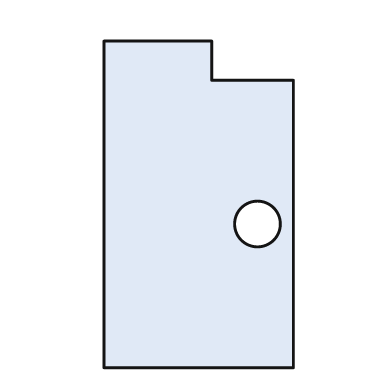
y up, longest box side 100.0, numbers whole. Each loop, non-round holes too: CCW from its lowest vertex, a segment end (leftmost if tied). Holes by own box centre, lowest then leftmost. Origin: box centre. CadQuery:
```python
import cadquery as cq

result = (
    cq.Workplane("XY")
    .moveTo(-29.0, -50.0)
    .lineTo(29.0, -50.0)
    .lineTo(29.0, 38.0)
    .lineTo(4.0, 38.0)
    .lineTo(4.0, 50.0)
    .lineTo(-29.0, 50.0)
    .close()
    .moveTo(18.0, -6.0)
    .circle(7.0)
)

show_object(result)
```